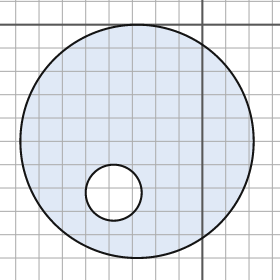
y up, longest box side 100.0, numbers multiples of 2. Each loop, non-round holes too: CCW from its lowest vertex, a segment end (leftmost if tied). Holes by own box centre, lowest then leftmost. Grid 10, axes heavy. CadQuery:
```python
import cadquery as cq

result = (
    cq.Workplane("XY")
    .moveTo(-28.0, -50.0)
    .circle(50.0)
    .moveTo(-38.0, -72.0)
    .circle(12.0)
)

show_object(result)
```